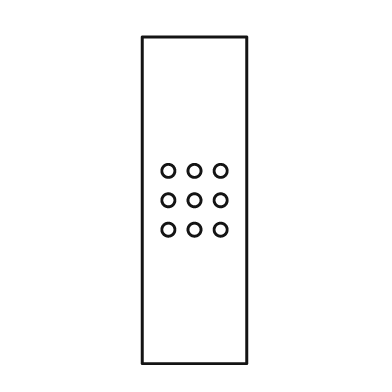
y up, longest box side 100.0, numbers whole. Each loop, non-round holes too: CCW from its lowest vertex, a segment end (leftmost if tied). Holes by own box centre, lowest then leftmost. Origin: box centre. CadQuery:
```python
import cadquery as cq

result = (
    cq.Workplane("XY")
    .moveTo(-16.0, -50.0)
    .lineTo(16.0, -50.0)
    .lineTo(16.0, 50.0)
    .lineTo(-16.0, 50.0)
    .close()
    .moveTo(-8.0, -9.0)
    .circle(2.0)
    .moveTo(0.0, -9.0)
    .circle(2.0)
    .moveTo(8.0, -9.0)
    .circle(2.0)
    .moveTo(-8.0, 0.0)
    .circle(2.0)
    .moveTo(0.0, 0.0)
    .circle(2.0)
    .moveTo(8.0, 0.0)
    .circle(2.0)
    .moveTo(-8.0, 9.0)
    .circle(2.0)
    .moveTo(0.0, 9.0)
    .circle(2.0)
    .moveTo(8.0, 9.0)
    .circle(2.0)
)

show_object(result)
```